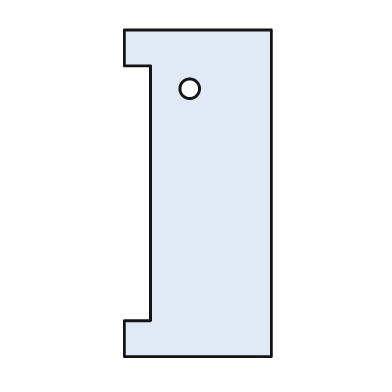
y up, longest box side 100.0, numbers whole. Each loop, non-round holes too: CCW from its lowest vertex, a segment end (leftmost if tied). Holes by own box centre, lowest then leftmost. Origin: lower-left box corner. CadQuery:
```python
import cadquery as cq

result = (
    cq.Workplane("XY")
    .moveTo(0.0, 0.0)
    .lineTo(45.0, 0.0)
    .lineTo(45.0, 100.0)
    .lineTo(0.0, 100.0)
    .lineTo(0.0, 89.0)
    .lineTo(8.0, 89.0)
    .lineTo(8.0, 11.0)
    .lineTo(0.0, 11.0)
    .close()
    .moveTo(20.0, 82.0)
    .circle(3.0)
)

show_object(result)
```